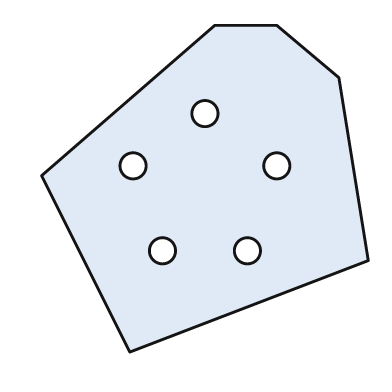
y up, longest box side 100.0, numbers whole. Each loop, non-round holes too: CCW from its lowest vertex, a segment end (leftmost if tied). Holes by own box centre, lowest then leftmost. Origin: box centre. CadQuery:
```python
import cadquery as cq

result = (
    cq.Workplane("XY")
    .moveTo(-23.0, -50.0)
    .lineTo(50.0, -22.0)
    .lineTo(41.0, 34.0)
    .lineTo(22.0, 50.0)
    .lineTo(3.0, 50.0)
    .lineTo(-50.0, 4.0)
    .close()
    .moveTo(-13.0, -19.0)
    .circle(4.0)
    .moveTo(13.0, -19.0)
    .circle(4.0)
    .moveTo(-22.0, 7.0)
    .circle(4.0)
    .moveTo(22.0, 7.0)
    .circle(4.0)
    .moveTo(0.0, 23.0)
    .circle(4.0)
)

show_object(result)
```